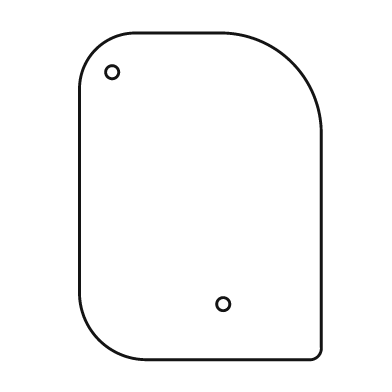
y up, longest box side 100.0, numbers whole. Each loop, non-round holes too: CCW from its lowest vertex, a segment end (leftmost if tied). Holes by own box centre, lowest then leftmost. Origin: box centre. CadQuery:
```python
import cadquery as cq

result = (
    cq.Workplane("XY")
    .moveTo(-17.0, -50.0)
    .lineTo(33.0, -50.0)
    .threePointArc((36.0, -49.0), (37.0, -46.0))
    .lineTo(37.0, 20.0)
    .threePointArc((28.0, 41.0), (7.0, 50.0))
    .lineTo(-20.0, 50.0)
    .threePointArc((-32.0, 45.0), (-37.0, 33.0))
    .lineTo(-37.0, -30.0)
    .threePointArc((-31.0, -44.0), (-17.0, -50.0))
    .close()
    .moveTo(7.0, -33.0)
    .circle(2.0)
    .moveTo(-27.0, 38.0)
    .circle(2.0)
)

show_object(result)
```